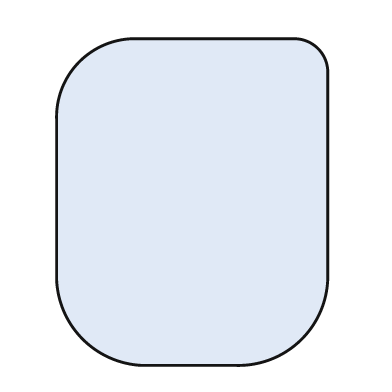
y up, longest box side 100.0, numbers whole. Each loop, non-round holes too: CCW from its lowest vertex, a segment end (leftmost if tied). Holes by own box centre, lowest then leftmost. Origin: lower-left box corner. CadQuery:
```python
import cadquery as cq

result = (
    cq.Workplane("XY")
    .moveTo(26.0, 0.0)
    .lineTo(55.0, 0.0)
    .threePointArc((75.0, 8.0), (83.0, 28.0))
    .lineTo(83.0, 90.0)
    .threePointArc((80.0, 97.0), (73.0, 100.0))
    .lineTo(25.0, 100.0)
    .threePointArc((7.0, 93.0), (0.0, 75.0))
    .lineTo(0.0, 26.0)
    .threePointArc((8.0, 8.0), (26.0, 0.0))
    .close()
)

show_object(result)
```